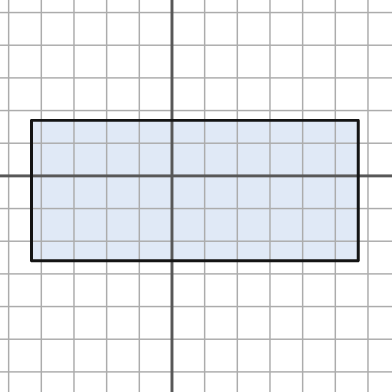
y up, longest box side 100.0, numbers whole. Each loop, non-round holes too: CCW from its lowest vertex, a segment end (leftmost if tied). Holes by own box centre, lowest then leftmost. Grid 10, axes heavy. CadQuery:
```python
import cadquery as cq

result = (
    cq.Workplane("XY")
    .moveTo(-43.0, -26.0)
    .lineTo(57.0, -26.0)
    .lineTo(57.0, 17.0)
    .lineTo(-43.0, 17.0)
    .close()
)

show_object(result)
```